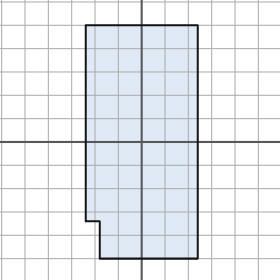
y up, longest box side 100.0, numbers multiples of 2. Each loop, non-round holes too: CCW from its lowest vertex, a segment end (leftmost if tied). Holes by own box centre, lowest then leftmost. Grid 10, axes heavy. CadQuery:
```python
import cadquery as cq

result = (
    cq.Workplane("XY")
    .moveTo(-18.0, -50.0)
    .lineTo(24.0, -50.0)
    .lineTo(24.0, 50.0)
    .lineTo(-24.0, 50.0)
    .lineTo(-24.0, -34.0)
    .lineTo(-18.0, -34.0)
    .close()
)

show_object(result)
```